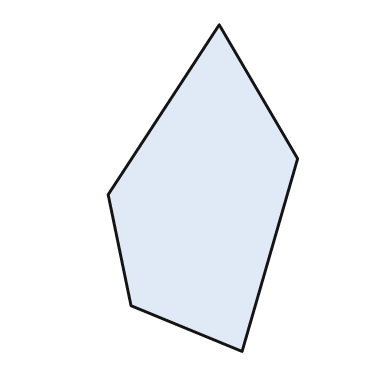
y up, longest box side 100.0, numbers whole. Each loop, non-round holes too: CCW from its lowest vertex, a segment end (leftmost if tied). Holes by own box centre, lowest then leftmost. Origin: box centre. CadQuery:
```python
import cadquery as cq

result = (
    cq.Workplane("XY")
    .moveTo(12.0, -50.0)
    .lineTo(29.0, 9.0)
    .lineTo(5.0, 50.0)
    .lineTo(-29.0, -2.0)
    .lineTo(-22.0, -36.0)
    .close()
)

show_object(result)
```